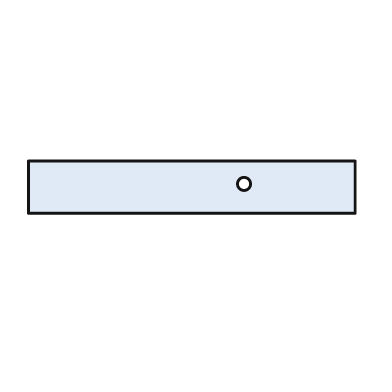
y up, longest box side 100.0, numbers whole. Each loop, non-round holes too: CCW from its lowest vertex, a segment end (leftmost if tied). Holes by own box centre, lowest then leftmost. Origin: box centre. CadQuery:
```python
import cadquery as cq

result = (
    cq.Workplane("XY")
    .moveTo(-50.0, -8.0)
    .lineTo(50.0, -8.0)
    .lineTo(50.0, 8.0)
    .lineTo(-50.0, 8.0)
    .close()
    .moveTo(16.0, 1.0)
    .circle(2.0)
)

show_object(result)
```